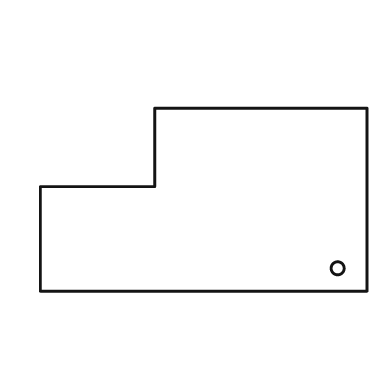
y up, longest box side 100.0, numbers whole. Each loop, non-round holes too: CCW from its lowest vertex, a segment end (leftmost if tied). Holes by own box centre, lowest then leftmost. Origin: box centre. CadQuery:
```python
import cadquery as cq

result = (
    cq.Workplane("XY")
    .moveTo(-50.0, -28.0)
    .lineTo(50.0, -28.0)
    .lineTo(50.0, 28.0)
    .lineTo(-15.0, 28.0)
    .lineTo(-15.0, 4.0)
    .lineTo(-50.0, 4.0)
    .close()
    .moveTo(41.0, -21.0)
    .circle(2.0)
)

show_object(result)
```